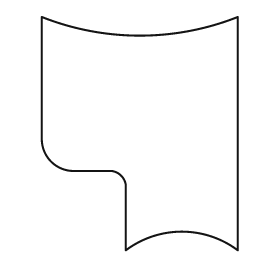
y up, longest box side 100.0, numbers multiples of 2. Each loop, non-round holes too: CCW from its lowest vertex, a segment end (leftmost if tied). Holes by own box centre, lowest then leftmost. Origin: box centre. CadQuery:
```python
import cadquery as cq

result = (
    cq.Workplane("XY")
    .moveTo(-6.0, -50.0)
    .threePointArc((18.0, -42.0), (42.0, -50.0))
    .lineTo(42.0, 50.0)
    .threePointArc((0.0, 42.0), (-42.0, 50.0))
    .lineTo(-42.0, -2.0)
    .threePointArc((-38.0, -12.0), (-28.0, -16.0))
    .lineTo(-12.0, -16.0)
    .threePointArc((-8.0, -18.0), (-6.0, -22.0))
    .close()
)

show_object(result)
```